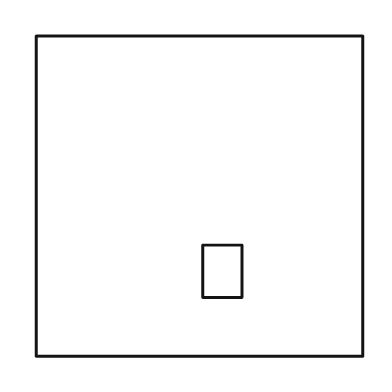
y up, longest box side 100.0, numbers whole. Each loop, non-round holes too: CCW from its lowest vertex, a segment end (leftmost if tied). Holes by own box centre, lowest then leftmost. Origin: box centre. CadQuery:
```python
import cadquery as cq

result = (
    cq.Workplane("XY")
    .moveTo(-50.0, -49.0)
    .lineTo(50.0, -49.0)
    .lineTo(50.0, 49.0)
    .lineTo(-50.0, 49.0)
    .close()
    .moveTo(1.0, -31.0)
    .lineTo(13.0, -31.0)
    .lineTo(13.0, -15.0)
    .lineTo(1.0, -15.0)
    .close()
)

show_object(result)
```